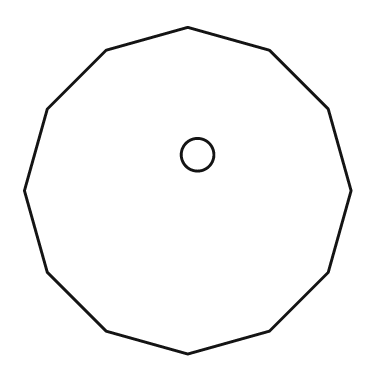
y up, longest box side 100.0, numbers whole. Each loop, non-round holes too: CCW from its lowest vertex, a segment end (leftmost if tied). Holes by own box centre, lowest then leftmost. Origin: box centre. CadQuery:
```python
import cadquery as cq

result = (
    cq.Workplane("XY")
    .moveTo(0.0, -50.0)
    .lineTo(25.0, -43.0)
    .lineTo(43.0, -25.0)
    .lineTo(50.0, 0.0)
    .lineTo(43.0, 25.0)
    .lineTo(25.0, 43.0)
    .lineTo(0.0, 50.0)
    .lineTo(-25.0, 43.0)
    .lineTo(-43.0, 25.0)
    .lineTo(-50.0, 0.0)
    .lineTo(-43.0, -25.0)
    .lineTo(-25.0, -43.0)
    .close()
    .moveTo(3.0, 11.0)
    .circle(5.0)
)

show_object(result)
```